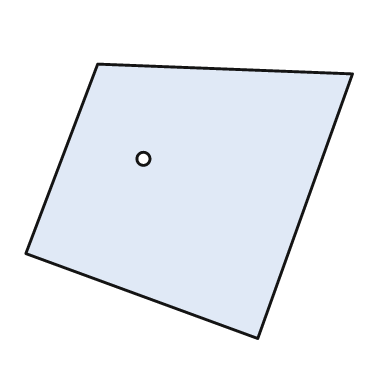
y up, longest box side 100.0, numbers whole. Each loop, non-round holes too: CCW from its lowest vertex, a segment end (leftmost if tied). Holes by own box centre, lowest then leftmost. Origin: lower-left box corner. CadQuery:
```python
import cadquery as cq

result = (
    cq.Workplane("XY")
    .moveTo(71.0, 0.0)
    .lineTo(100.0, 81.0)
    .lineTo(22.0, 84.0)
    .lineTo(0.0, 26.0)
    .close()
    .moveTo(36.0, 55.0)
    .circle(2.0)
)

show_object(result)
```